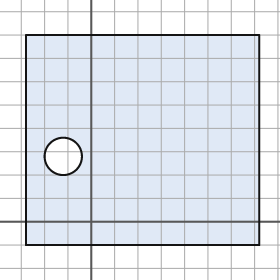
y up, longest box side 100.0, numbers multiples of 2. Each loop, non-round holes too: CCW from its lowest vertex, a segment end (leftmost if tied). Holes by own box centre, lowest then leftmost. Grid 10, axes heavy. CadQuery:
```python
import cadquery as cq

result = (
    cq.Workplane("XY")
    .moveTo(-28.0, -10.0)
    .lineTo(72.0, -10.0)
    .lineTo(72.0, 80.0)
    .lineTo(-28.0, 80.0)
    .close()
    .moveTo(-12.0, 28.0)
    .circle(8.0)
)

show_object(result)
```